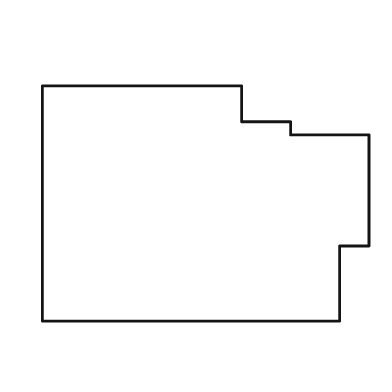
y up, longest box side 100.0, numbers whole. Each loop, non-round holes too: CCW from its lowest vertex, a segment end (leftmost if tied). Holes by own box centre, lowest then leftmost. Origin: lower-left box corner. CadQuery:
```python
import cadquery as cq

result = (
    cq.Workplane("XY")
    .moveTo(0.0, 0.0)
    .lineTo(91.0, 0.0)
    .lineTo(91.0, 23.0)
    .lineTo(100.0, 23.0)
    .lineTo(100.0, 57.0)
    .lineTo(76.0, 57.0)
    .lineTo(76.0, 61.0)
    .lineTo(61.0, 61.0)
    .lineTo(61.0, 72.0)
    .lineTo(0.0, 72.0)
    .close()
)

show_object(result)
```